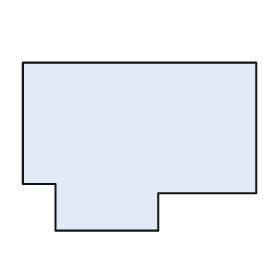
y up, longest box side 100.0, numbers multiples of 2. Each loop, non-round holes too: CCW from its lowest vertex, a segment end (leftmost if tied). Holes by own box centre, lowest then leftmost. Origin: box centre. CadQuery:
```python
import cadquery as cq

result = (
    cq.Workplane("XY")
    .moveTo(-36.0, -36.0)
    .lineTo(8.0, -36.0)
    .lineTo(8.0, -20.0)
    .lineTo(50.0, -20.0)
    .lineTo(50.0, 36.0)
    .lineTo(-50.0, 36.0)
    .lineTo(-50.0, -16.0)
    .lineTo(-36.0, -16.0)
    .close()
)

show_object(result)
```